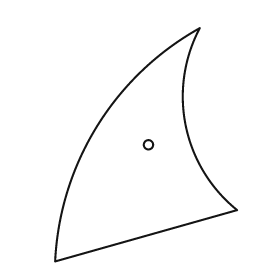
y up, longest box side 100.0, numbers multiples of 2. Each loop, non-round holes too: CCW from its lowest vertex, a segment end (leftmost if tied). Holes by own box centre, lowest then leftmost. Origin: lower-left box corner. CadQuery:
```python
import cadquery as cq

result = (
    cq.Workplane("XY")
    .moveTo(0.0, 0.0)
    .lineTo(78.0, 22.0)
    .threePointArc((56.0, 58.0), (62.0, 100.0))
    .threePointArc((18.0, 58.0), (0.0, 0.0))
    .close()
    .moveTo(40.0, 50.0)
    .circle(2.0)
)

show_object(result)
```